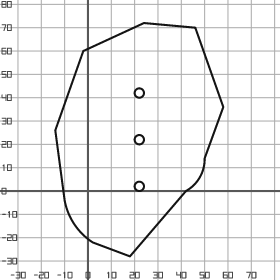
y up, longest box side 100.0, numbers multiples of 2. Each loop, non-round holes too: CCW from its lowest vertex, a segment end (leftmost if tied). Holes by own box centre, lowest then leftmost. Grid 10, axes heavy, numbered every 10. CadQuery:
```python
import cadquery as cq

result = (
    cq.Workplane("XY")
    .moveTo(18.0, -28.0)
    .lineTo(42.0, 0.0)
    .threePointArc((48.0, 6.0), (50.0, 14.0))
    .lineTo(58.0, 36.0)
    .lineTo(46.0, 70.0)
    .lineTo(24.0, 72.0)
    .lineTo(-2.0, 60.0)
    .lineTo(-14.0, 26.0)
    .lineTo(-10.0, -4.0)
    .threePointArc((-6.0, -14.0), (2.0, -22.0))
    .close()
    .moveTo(22.0, 2.0)
    .circle(2.0)
    .moveTo(22.0, 22.0)
    .circle(2.0)
    .moveTo(22.0, 42.0)
    .circle(2.0)
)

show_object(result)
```